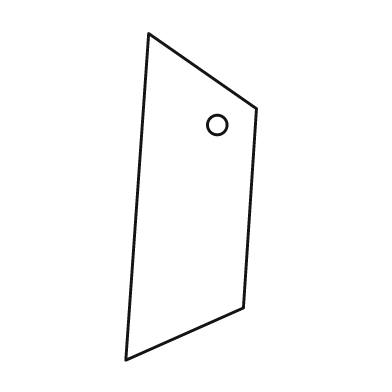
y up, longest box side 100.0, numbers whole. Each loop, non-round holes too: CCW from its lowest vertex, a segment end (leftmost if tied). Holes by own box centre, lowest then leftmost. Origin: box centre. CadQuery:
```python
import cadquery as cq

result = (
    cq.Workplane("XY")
    .moveTo(-20.0, -50.0)
    .lineTo(16.0, -34.0)
    .lineTo(20.0, 27.0)
    .lineTo(-13.0, 50.0)
    .close()
    .moveTo(8.0, 22.0)
    .circle(3.0)
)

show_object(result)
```